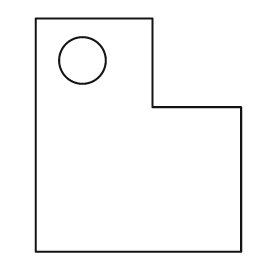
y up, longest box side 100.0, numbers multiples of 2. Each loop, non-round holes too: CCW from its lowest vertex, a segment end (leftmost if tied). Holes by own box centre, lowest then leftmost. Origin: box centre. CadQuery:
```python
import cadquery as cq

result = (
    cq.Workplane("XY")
    .moveTo(-44.0, -50.0)
    .lineTo(44.0, -50.0)
    .lineTo(44.0, 12.0)
    .lineTo(6.0, 12.0)
    .lineTo(6.0, 50.0)
    .lineTo(-44.0, 50.0)
    .close()
    .moveTo(-24.0, 32.0)
    .circle(10.0)
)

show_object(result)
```